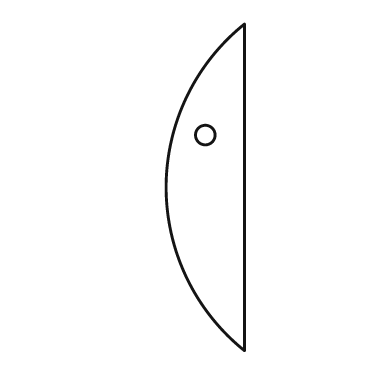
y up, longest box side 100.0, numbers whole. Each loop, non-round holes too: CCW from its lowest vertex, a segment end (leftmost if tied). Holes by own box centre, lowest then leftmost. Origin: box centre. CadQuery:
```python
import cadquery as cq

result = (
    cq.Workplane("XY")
    .moveTo(12.0, -50.0)
    .lineTo(12.0, 50.0)
    .threePointArc((-12.0, 0.0), (12.0, -50.0))
    .close()
    .moveTo(0.0, 16.0)
    .circle(3.0)
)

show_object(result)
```